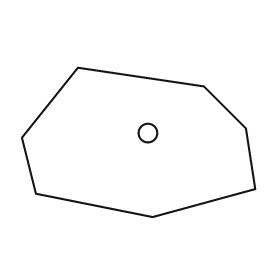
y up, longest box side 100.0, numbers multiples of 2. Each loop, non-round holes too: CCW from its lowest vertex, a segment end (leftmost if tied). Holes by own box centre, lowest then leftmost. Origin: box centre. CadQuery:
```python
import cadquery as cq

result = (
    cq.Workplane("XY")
    .moveTo(6.0, -32.0)
    .lineTo(50.0, -20.0)
    .lineTo(46.0, 6.0)
    .lineTo(28.0, 24.0)
    .lineTo(-26.0, 32.0)
    .lineTo(-50.0, 2.0)
    .lineTo(-44.0, -22.0)
    .close()
    .moveTo(4.0, 4.0)
    .circle(4.0)
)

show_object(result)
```